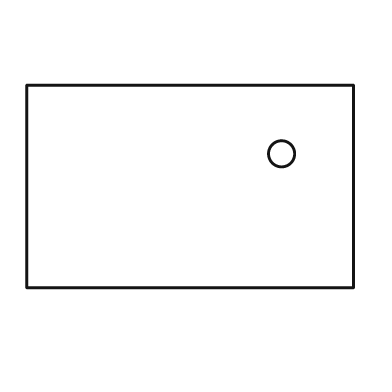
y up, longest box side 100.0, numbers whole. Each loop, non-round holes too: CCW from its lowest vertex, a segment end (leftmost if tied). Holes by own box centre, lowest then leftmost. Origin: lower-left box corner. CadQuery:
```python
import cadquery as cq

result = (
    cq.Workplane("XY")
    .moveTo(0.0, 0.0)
    .lineTo(100.0, 0.0)
    .lineTo(100.0, 62.0)
    .lineTo(0.0, 62.0)
    .close()
    .moveTo(78.0, 41.0)
    .circle(4.0)
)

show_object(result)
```